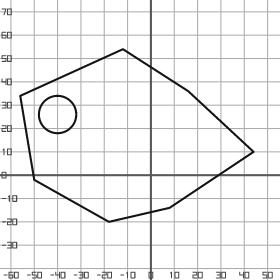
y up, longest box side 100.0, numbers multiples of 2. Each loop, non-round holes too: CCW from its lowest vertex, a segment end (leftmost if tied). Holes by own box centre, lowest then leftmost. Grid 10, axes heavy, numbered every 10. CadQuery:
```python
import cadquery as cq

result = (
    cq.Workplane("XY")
    .moveTo(-18.0, -20.0)
    .lineTo(8.0, -14.0)
    .lineTo(44.0, 10.0)
    .lineTo(16.0, 36.0)
    .lineTo(-12.0, 54.0)
    .lineTo(-56.0, 34.0)
    .lineTo(-50.0, -2.0)
    .close()
    .moveTo(-40.0, 26.0)
    .circle(8.0)
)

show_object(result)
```